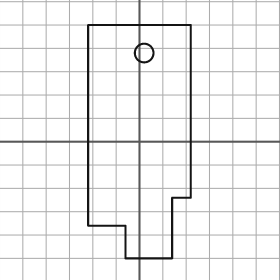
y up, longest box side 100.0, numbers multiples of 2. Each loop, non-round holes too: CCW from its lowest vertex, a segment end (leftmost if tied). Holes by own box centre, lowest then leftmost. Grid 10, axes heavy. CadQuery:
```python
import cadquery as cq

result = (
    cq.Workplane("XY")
    .moveTo(-6.0, -50.0)
    .lineTo(14.0, -50.0)
    .lineTo(14.0, -24.0)
    .lineTo(22.0, -24.0)
    .lineTo(22.0, 50.0)
    .lineTo(-22.0, 50.0)
    .lineTo(-22.0, -36.0)
    .lineTo(-6.0, -36.0)
    .close()
    .moveTo(2.0, 38.0)
    .circle(4.0)
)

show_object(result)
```